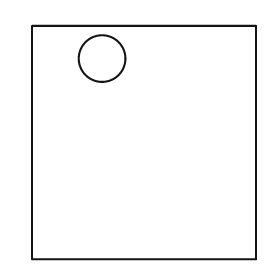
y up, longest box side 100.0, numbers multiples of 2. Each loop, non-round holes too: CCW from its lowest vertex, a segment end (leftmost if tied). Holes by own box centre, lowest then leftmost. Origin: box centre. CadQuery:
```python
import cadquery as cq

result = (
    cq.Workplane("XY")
    .moveTo(-48.0, -50.0)
    .lineTo(48.0, -50.0)
    .lineTo(48.0, 50.0)
    .lineTo(-48.0, 50.0)
    .close()
    .moveTo(-18.0, 36.0)
    .circle(10.0)
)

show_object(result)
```